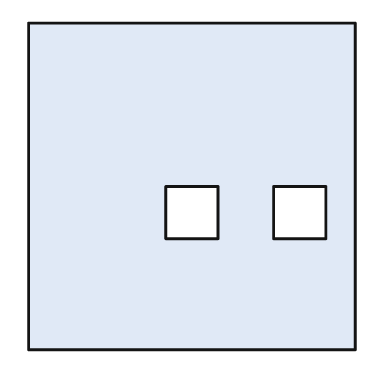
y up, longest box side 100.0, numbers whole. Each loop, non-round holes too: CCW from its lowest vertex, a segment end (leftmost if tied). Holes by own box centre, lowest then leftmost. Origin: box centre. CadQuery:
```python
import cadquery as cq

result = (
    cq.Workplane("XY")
    .moveTo(-50.0, -50.0)
    .lineTo(50.0, -50.0)
    .lineTo(50.0, 50.0)
    .lineTo(-50.0, 50.0)
    .close()
    .moveTo(-8.0, -16.0)
    .lineTo(8.0, -16.0)
    .lineTo(8.0, 0.0)
    .lineTo(-8.0, 0.0)
    .close()
    .moveTo(25.0, -16.0)
    .lineTo(41.0, -16.0)
    .lineTo(41.0, 0.0)
    .lineTo(25.0, 0.0)
    .close()
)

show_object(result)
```